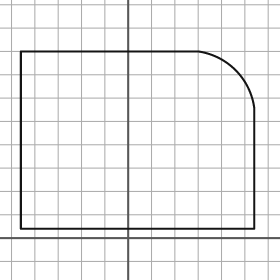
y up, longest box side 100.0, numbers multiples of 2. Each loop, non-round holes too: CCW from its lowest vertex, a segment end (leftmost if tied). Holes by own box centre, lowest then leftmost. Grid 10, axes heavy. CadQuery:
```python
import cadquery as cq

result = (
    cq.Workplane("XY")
    .moveTo(-46.0, 4.0)
    .lineTo(54.0, 4.0)
    .lineTo(54.0, 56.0)
    .threePointArc((46.0, 72.0), (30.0, 80.0))
    .lineTo(-46.0, 80.0)
    .close()
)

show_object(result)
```